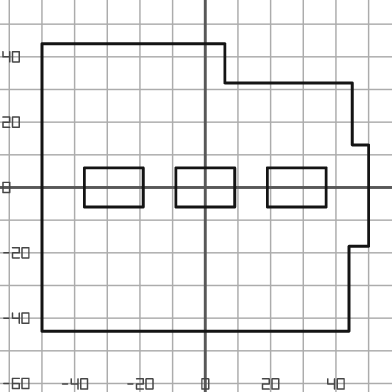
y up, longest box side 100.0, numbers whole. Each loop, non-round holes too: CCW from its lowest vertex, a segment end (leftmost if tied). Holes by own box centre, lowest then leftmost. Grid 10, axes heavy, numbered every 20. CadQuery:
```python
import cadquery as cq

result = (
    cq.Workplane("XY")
    .moveTo(-50.0, -44.0)
    .lineTo(44.0, -44.0)
    .lineTo(44.0, -18.0)
    .lineTo(50.0, -18.0)
    .lineTo(50.0, 13.0)
    .lineTo(45.0, 13.0)
    .lineTo(45.0, 32.0)
    .lineTo(6.0, 32.0)
    .lineTo(6.0, 44.0)
    .lineTo(-50.0, 44.0)
    .close()
    .moveTo(-37.0, -6.0)
    .lineTo(-19.0, -6.0)
    .lineTo(-19.0, 6.0)
    .lineTo(-37.0, 6.0)
    .close()
    .moveTo(-9.0, -6.0)
    .lineTo(9.0, -6.0)
    .lineTo(9.0, 6.0)
    .lineTo(-9.0, 6.0)
    .close()
    .moveTo(19.0, -6.0)
    .lineTo(37.0, -6.0)
    .lineTo(37.0, 6.0)
    .lineTo(19.0, 6.0)
    .close()
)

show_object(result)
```